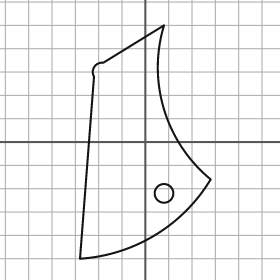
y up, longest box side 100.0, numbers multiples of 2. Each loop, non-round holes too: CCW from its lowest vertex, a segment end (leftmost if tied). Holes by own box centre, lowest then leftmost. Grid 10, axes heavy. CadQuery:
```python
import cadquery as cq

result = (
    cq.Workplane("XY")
    .moveTo(-28.0, -50.0)
    .threePointArc((4.0, -40.0), (28.0, -16.0))
    .threePointArc((8.0, 14.0), (8.0, 50.0))
    .lineTo(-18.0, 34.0)
    .threePointArc((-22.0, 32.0), (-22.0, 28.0))
    .close()
    .moveTo(8.0, -22.0)
    .circle(4.0)
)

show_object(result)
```